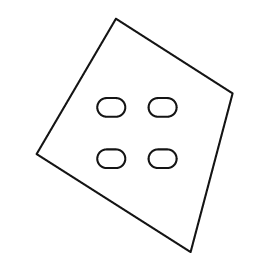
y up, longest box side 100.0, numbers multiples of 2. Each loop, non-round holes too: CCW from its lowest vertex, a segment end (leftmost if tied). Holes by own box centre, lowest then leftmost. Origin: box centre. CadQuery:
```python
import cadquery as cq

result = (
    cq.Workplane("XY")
    .moveTo(24.0, -50.0)
    .lineTo(42.0, 18.0)
    .lineTo(-8.0, 50.0)
    .lineTo(-42.0, -8.0)
    .close()
    .moveTo(-12.0, -14.0)
    .lineTo(-8.0, -14.0)
    .threePointArc((-4.0, -10.0), (-8.0, -6.0))
    .lineTo(-12.0, -6.0)
    .threePointArc((-16.0, -10.0), (-12.0, -14.0))
    .close()
    .moveTo(10.0, -14.0)
    .lineTo(14.0, -14.0)
    .threePointArc((18.0, -10.0), (14.0, -6.0))
    .lineTo(10.0, -6.0)
    .threePointArc((6.0, -10.0), (10.0, -14.0))
    .close()
    .moveTo(-12.0, 8.0)
    .lineTo(-8.0, 8.0)
    .threePointArc((-4.0, 12.0), (-8.0, 16.0))
    .lineTo(-12.0, 16.0)
    .threePointArc((-16.0, 12.0), (-12.0, 8.0))
    .close()
    .moveTo(10.0, 8.0)
    .lineTo(14.0, 8.0)
    .threePointArc((18.0, 12.0), (14.0, 16.0))
    .lineTo(10.0, 16.0)
    .threePointArc((6.0, 12.0), (10.0, 8.0))
    .close()
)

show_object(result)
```